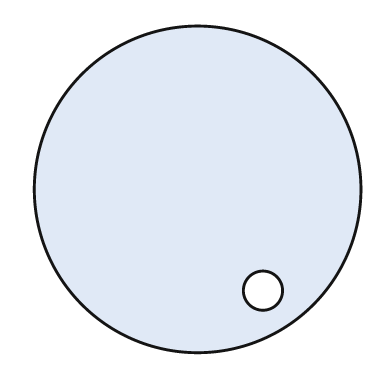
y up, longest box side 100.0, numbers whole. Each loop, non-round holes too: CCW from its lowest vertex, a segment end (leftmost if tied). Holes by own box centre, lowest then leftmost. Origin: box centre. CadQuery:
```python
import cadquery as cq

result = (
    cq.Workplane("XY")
    .moveTo(0.0, 0.0)
    .circle(50.0)
    .moveTo(20.0, -31.0)
    .circle(6.0)
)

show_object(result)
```